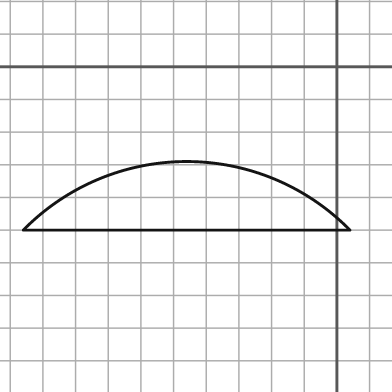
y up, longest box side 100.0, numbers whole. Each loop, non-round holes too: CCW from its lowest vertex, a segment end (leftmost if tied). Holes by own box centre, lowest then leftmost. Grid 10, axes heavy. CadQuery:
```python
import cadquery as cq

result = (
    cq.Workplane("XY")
    .moveTo(-96.0, -50.0)
    .lineTo(4.0, -50.0)
    .threePointArc((-46.0, -29.0), (-96.0, -50.0))
    .close()
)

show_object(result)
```